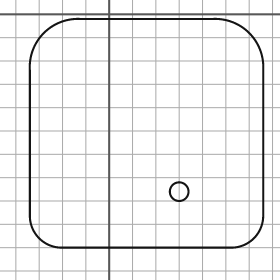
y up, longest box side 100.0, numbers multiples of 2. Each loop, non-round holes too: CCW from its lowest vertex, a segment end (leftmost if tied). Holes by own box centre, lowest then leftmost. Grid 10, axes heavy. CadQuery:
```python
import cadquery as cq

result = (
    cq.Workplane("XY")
    .moveTo(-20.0, -100.0)
    .lineTo(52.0, -100.0)
    .threePointArc((62.0, -96.0), (66.0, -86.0))
    .lineTo(66.0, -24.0)
    .threePointArc((60.0, -8.0), (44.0, -2.0))
    .lineTo(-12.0, -2.0)
    .threePointArc((-28.0, -8.0), (-34.0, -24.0))
    .lineTo(-34.0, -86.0)
    .threePointArc((-30.0, -96.0), (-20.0, -100.0))
    .close()
    .moveTo(30.0, -76.0)
    .circle(4.0)
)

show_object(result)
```